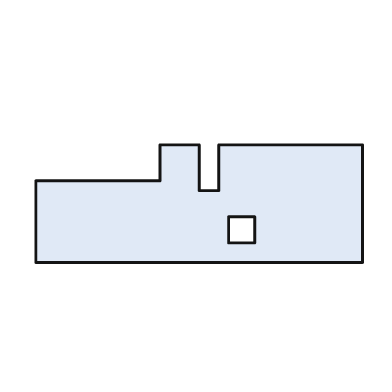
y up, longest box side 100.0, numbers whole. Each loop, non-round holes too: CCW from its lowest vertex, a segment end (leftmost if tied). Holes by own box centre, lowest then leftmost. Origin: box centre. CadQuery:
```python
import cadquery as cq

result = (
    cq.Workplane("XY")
    .moveTo(-50.0, -18.0)
    .lineTo(50.0, -18.0)
    .lineTo(50.0, 18.0)
    .lineTo(6.0, 18.0)
    .lineTo(6.0, 4.0)
    .lineTo(0.0, 4.0)
    .lineTo(0.0, 18.0)
    .lineTo(-12.0, 18.0)
    .lineTo(-12.0, 7.0)
    .lineTo(-50.0, 7.0)
    .close()
    .moveTo(9.0, -12.0)
    .lineTo(17.0, -12.0)
    .lineTo(17.0, -4.0)
    .lineTo(9.0, -4.0)
    .close()
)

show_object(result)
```